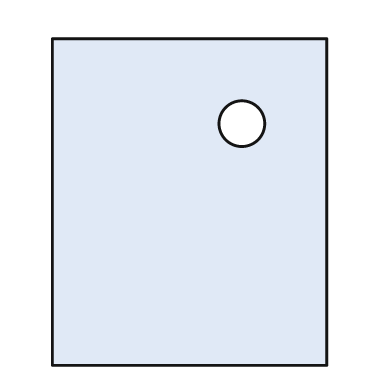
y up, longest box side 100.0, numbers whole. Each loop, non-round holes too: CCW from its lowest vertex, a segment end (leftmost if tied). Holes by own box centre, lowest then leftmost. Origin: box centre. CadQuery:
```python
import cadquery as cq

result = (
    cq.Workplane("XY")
    .moveTo(-42.0, -50.0)
    .lineTo(42.0, -50.0)
    .lineTo(42.0, 50.0)
    .lineTo(-42.0, 50.0)
    .close()
    .moveTo(16.0, 24.0)
    .circle(7.0)
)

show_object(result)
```